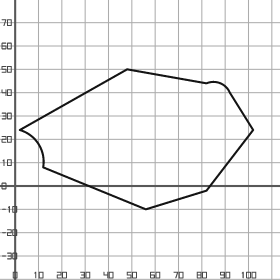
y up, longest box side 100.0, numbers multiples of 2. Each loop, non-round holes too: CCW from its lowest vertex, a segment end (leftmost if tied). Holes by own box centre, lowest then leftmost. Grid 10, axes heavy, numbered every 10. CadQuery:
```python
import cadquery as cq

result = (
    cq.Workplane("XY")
    .moveTo(56.0, -10.0)
    .lineTo(82.0, -2.0)
    .lineTo(102.0, 24.0)
    .lineTo(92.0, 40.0)
    .threePointArc((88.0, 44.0), (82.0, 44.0))
    .lineTo(48.0, 50.0)
    .lineTo(2.0, 24.0)
    .threePointArc((10.0, 18.0), (12.0, 8.0))
    .close()
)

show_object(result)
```